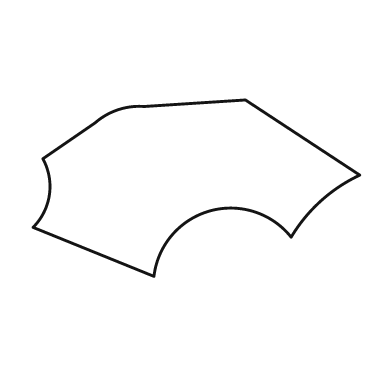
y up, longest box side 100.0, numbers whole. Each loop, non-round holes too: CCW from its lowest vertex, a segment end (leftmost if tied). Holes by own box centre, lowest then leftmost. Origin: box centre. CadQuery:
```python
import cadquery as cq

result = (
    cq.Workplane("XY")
    .moveTo(-13.0, -27.0)
    .threePointArc((4.0, -7.0), (29.0, -15.0))
    .threePointArc((38.0, -4.0), (50.0, 4.0))
    .lineTo(15.0, 27.0)
    .lineTo(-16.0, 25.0)
    .threePointArc((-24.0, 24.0), (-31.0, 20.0))
    .lineTo(-47.0, 9.0)
    .threePointArc((-45.0, -2.0), (-50.0, -12.0))
    .close()
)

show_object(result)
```